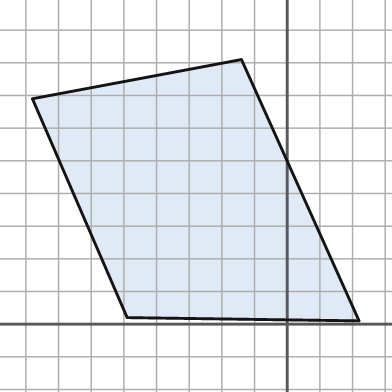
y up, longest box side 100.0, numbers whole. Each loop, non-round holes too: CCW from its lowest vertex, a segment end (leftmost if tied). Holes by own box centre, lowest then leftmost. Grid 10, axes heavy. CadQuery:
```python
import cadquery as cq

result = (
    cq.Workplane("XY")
    .moveTo(22.0, 1.0)
    .lineTo(-14.0, 81.0)
    .lineTo(-78.0, 69.0)
    .lineTo(-49.0, 2.0)
    .close()
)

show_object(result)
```